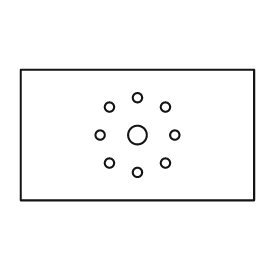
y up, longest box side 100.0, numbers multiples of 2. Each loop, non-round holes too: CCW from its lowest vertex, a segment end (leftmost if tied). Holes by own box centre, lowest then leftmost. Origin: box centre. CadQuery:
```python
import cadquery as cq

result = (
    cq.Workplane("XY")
    .moveTo(-50.0, -28.0)
    .lineTo(50.0, -28.0)
    .lineTo(50.0, 28.0)
    .lineTo(-50.0, 28.0)
    .close()
    .moveTo(0.0, -16.0)
    .circle(2.0)
    .moveTo(-12.0, -12.0)
    .circle(2.0)
    .moveTo(12.0, -12.0)
    .circle(2.0)
    .moveTo(-16.0, 0.0)
    .circle(2.0)
    .moveTo(0.0, 0.0)
    .circle(4.0)
    .moveTo(16.0, 0.0)
    .circle(2.0)
    .moveTo(-12.0, 12.0)
    .circle(2.0)
    .moveTo(12.0, 12.0)
    .circle(2.0)
    .moveTo(0.0, 16.0)
    .circle(2.0)
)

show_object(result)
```